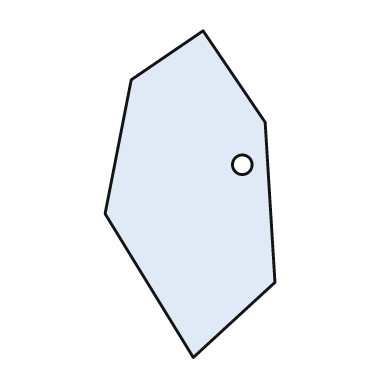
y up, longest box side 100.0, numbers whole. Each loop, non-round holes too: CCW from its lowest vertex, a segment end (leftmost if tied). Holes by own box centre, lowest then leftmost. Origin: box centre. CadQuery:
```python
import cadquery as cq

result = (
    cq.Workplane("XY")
    .moveTo(1.0, -50.0)
    .lineTo(26.0, -27.0)
    .lineTo(23.0, 22.0)
    .lineTo(4.0, 50.0)
    .lineTo(-18.0, 35.0)
    .lineTo(-26.0, -6.0)
    .close()
    .moveTo(16.0, 9.0)
    .circle(3.0)
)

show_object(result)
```